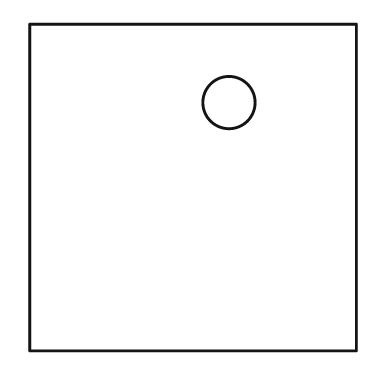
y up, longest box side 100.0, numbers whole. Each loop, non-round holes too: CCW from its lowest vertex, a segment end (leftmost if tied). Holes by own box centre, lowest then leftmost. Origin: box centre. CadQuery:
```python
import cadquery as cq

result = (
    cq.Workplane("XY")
    .moveTo(-50.0, -50.0)
    .lineTo(50.0, -50.0)
    .lineTo(50.0, 50.0)
    .lineTo(-50.0, 50.0)
    .close()
    .moveTo(11.0, 26.0)
    .circle(8.0)
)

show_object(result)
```